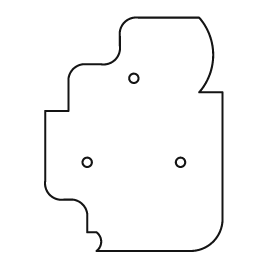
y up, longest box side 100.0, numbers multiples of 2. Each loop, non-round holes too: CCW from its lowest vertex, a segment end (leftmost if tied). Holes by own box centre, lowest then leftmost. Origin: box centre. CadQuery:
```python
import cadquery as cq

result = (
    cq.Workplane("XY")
    .moveTo(-16.0, -50.0)
    .lineTo(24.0, -50.0)
    .threePointArc((34.0, -46.0), (38.0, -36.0))
    .lineTo(38.0, 18.0)
    .lineTo(28.0, 18.0)
    .threePointArc((34.0, 34.0), (28.0, 50.0))
    .lineTo(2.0, 50.0)
    .threePointArc((-4.0, 48.0), (-6.0, 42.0))
    .lineTo(-6.0, 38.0)
    .threePointArc((-8.0, 32.0), (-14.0, 30.0))
    .lineTo(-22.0, 30.0)
    .threePointArc((-26.0, 28.0), (-28.0, 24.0))
    .lineTo(-28.0, 10.0)
    .lineTo(-38.0, 10.0)
    .lineTo(-38.0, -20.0)
    .threePointArc((-36.0, -26.0), (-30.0, -28.0))
    .lineTo(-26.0, -28.0)
    .threePointArc((-22.0, -30.0), (-20.0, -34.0))
    .lineTo(-20.0, -42.0)
    .lineTo(-16.0, -42.0)
    .threePointArc((-14.0, -46.0), (-16.0, -50.0))
    .close()
    .moveTo(-20.0, -12.0)
    .circle(2.0)
    .moveTo(20.0, -12.0)
    .circle(2.0)
    .moveTo(0.0, 24.0)
    .circle(2.0)
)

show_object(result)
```